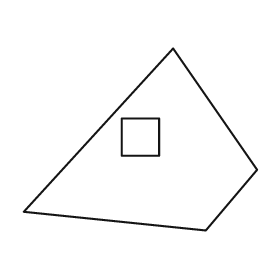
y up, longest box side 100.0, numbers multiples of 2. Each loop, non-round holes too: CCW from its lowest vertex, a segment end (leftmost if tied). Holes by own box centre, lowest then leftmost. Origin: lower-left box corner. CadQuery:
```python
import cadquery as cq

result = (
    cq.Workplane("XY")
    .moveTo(78.0, 0.0)
    .lineTo(100.0, 26.0)
    .lineTo(64.0, 78.0)
    .lineTo(0.0, 8.0)
    .close()
    .moveTo(42.0, 32.0)
    .lineTo(58.0, 32.0)
    .lineTo(58.0, 48.0)
    .lineTo(42.0, 48.0)
    .close()
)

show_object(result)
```